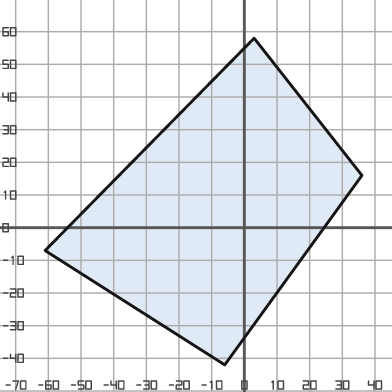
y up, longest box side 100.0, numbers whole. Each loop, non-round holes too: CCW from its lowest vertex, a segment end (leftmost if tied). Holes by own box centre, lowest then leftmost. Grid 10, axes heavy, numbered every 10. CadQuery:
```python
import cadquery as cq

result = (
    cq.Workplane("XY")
    .moveTo(-6.0, -42.0)
    .lineTo(36.0, 16.0)
    .lineTo(3.0, 58.0)
    .lineTo(-61.0, -7.0)
    .close()
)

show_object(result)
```